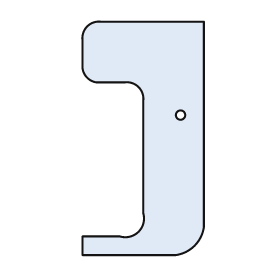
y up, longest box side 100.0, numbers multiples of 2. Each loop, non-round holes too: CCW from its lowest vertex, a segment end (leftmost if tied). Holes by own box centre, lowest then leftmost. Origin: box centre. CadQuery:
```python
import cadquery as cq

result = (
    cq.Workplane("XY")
    .moveTo(-26.0, -50.0)
    .lineTo(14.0, -50.0)
    .threePointArc((22.0, -46.0), (26.0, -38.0))
    .lineTo(26.0, 50.0)
    .lineTo(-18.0, 50.0)
    .threePointArc((-24.0, 48.0), (-26.0, 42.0))
    .lineTo(-26.0, 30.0)
    .threePointArc((-24.0, 26.0), (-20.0, 24.0))
    .lineTo(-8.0, 24.0)
    .threePointArc((-2.0, 22.0), (0.0, 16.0))
    .lineTo(0.0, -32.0)
    .threePointArc((-2.0, -40.0), (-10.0, -42.0))
    .lineTo(-26.0, -42.0)
    .close()
    .moveTo(16.0, 10.0)
    .circle(2.0)
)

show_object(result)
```